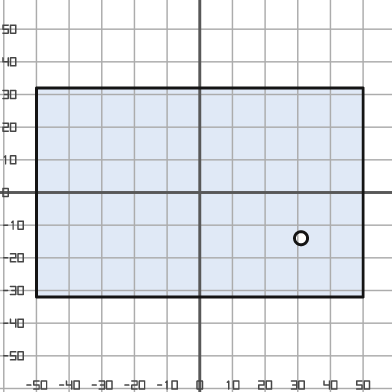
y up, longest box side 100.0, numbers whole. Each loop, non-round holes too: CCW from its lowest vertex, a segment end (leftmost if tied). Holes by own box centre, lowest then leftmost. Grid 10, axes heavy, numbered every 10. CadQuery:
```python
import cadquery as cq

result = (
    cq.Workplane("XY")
    .moveTo(-50.0, -32.0)
    .lineTo(50.0, -32.0)
    .lineTo(50.0, 32.0)
    .lineTo(-50.0, 32.0)
    .close()
    .moveTo(31.0, -14.0)
    .circle(2.0)
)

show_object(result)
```